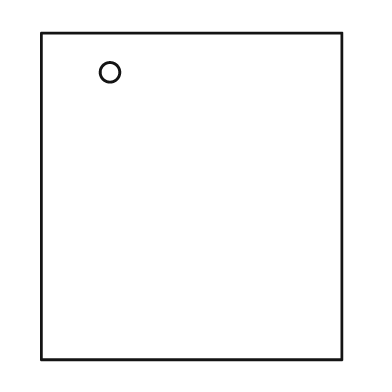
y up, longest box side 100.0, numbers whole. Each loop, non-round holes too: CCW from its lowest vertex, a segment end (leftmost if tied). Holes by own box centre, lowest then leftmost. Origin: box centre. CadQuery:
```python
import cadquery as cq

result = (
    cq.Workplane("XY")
    .moveTo(-46.0, -50.0)
    .lineTo(46.0, -50.0)
    .lineTo(46.0, 50.0)
    .lineTo(-46.0, 50.0)
    .close()
    .moveTo(-25.0, 38.0)
    .circle(3.0)
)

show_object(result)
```